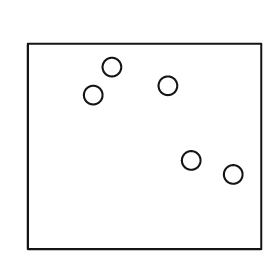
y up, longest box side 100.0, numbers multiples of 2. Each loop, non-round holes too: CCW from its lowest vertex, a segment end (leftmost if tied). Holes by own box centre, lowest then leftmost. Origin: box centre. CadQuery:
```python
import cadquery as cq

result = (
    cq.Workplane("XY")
    .moveTo(-50.0, -44.0)
    .lineTo(50.0, -44.0)
    .lineTo(50.0, 44.0)
    .lineTo(-50.0, 44.0)
    .close()
    .moveTo(38.0, -12.0)
    .circle(4.0)
    .moveTo(20.0, -6.0)
    .circle(4.0)
    .moveTo(-22.0, 22.0)
    .circle(4.0)
    .moveTo(10.0, 26.0)
    .circle(4.0)
    .moveTo(-14.0, 34.0)
    .circle(4.0)
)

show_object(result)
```